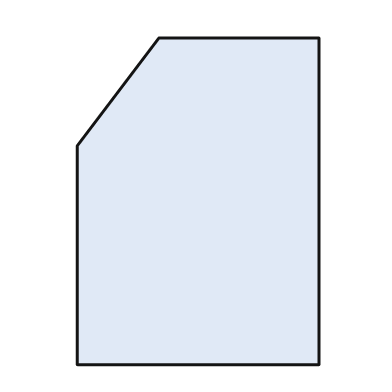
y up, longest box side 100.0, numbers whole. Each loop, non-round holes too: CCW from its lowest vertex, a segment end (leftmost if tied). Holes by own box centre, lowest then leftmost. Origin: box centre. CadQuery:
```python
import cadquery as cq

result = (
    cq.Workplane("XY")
    .moveTo(-37.0, -50.0)
    .lineTo(37.0, -50.0)
    .lineTo(37.0, 50.0)
    .lineTo(-12.0, 50.0)
    .lineTo(-37.0, 17.0)
    .close()
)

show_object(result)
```